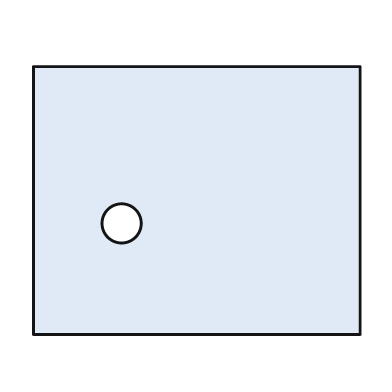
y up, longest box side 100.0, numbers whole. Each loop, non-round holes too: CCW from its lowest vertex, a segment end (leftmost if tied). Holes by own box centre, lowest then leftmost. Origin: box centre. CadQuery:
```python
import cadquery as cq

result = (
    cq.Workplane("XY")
    .moveTo(-50.0, -41.0)
    .lineTo(50.0, -41.0)
    .lineTo(50.0, 41.0)
    .lineTo(-50.0, 41.0)
    .close()
    .moveTo(-23.0, -7.0)
    .circle(6.0)
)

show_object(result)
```